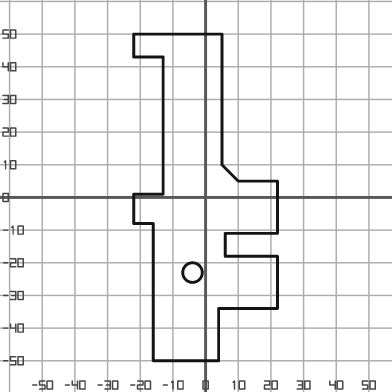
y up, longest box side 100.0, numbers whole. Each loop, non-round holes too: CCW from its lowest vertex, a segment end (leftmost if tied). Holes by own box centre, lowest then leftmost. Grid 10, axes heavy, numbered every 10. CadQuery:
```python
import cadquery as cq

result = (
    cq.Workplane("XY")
    .moveTo(-16.0, -50.0)
    .lineTo(4.0, -50.0)
    .lineTo(4.0, -34.0)
    .lineTo(22.0, -34.0)
    .lineTo(22.0, -18.0)
    .lineTo(6.0, -18.0)
    .lineTo(6.0, -11.0)
    .lineTo(22.0, -11.0)
    .lineTo(22.0, 5.0)
    .lineTo(10.0, 5.0)
    .lineTo(5.0, 10.0)
    .lineTo(5.0, 50.0)
    .lineTo(-22.0, 50.0)
    .lineTo(-22.0, 43.0)
    .lineTo(-13.0, 43.0)
    .lineTo(-13.0, 1.0)
    .lineTo(-22.0, 1.0)
    .lineTo(-22.0, -8.0)
    .lineTo(-16.0, -8.0)
    .close()
    .moveTo(-4.0, -23.0)
    .circle(3.0)
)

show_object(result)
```